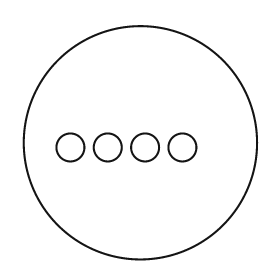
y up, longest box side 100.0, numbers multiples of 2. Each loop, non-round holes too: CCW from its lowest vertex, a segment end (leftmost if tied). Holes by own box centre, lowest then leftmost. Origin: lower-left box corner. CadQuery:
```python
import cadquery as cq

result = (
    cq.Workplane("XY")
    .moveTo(50.0, 50.0)
    .circle(50.0)
    .moveTo(20.0, 48.0)
    .circle(6.0)
    .moveTo(36.0, 48.0)
    .circle(6.0)
    .moveTo(52.0, 48.0)
    .circle(6.0)
    .moveTo(68.0, 48.0)
    .circle(6.0)
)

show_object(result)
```